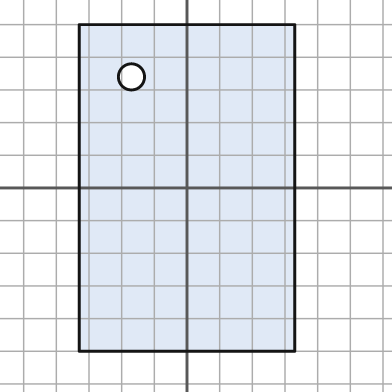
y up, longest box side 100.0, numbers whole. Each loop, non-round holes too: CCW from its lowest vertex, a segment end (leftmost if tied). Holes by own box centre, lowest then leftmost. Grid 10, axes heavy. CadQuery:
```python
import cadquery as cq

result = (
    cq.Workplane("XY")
    .moveTo(-33.0, -50.0)
    .lineTo(33.0, -50.0)
    .lineTo(33.0, 50.0)
    .lineTo(-33.0, 50.0)
    .close()
    .moveTo(-17.0, 34.0)
    .circle(4.0)
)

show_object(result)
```